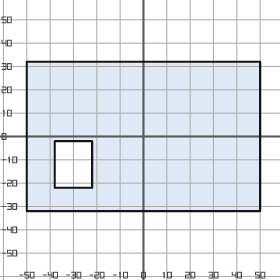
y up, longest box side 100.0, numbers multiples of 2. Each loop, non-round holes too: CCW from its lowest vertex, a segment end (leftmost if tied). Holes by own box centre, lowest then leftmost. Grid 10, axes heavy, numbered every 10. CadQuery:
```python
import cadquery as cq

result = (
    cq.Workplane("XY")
    .moveTo(-50.0, -32.0)
    .lineTo(50.0, -32.0)
    .lineTo(50.0, 32.0)
    .lineTo(-50.0, 32.0)
    .close()
    .moveTo(-38.0, -22.0)
    .lineTo(-22.0, -22.0)
    .lineTo(-22.0, -2.0)
    .lineTo(-38.0, -2.0)
    .close()
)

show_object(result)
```